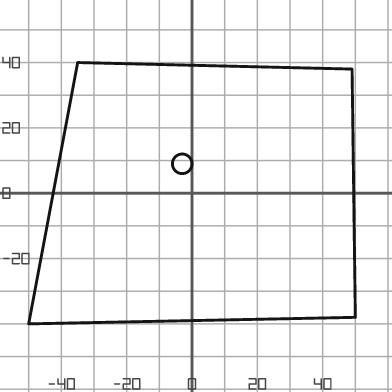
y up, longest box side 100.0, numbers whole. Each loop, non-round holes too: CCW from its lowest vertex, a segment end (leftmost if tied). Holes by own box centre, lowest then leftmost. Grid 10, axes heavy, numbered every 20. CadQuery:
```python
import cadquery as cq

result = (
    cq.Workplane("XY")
    .moveTo(-50.0, -40.0)
    .lineTo(50.0, -38.0)
    .lineTo(49.0, 38.0)
    .lineTo(-35.0, 40.0)
    .close()
    .moveTo(-3.0, 9.0)
    .circle(3.0)
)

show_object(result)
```